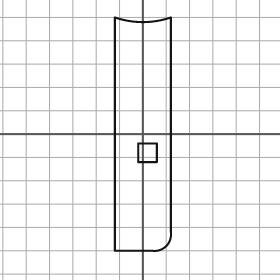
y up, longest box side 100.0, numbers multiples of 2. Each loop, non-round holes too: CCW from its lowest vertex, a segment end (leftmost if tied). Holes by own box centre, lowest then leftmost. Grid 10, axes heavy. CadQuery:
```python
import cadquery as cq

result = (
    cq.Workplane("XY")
    .moveTo(-12.0, -50.0)
    .lineTo(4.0, -50.0)
    .threePointArc((10.0, -48.0), (12.0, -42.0))
    .lineTo(12.0, 50.0)
    .threePointArc((0.0, 48.0), (-12.0, 50.0))
    .close()
    .moveTo(-2.0, -12.0)
    .lineTo(6.0, -12.0)
    .lineTo(6.0, -4.0)
    .lineTo(-2.0, -4.0)
    .close()
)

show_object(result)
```